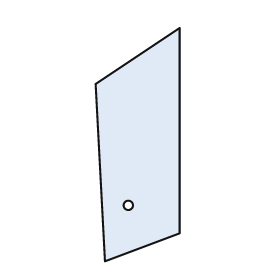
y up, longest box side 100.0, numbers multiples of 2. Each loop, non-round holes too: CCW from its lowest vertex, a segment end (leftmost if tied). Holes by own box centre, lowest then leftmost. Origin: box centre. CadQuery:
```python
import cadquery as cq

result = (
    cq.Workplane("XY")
    .moveTo(-14.0, -50.0)
    .lineTo(18.0, -38.0)
    .lineTo(18.0, 50.0)
    .lineTo(-18.0, 26.0)
    .close()
    .moveTo(-4.0, -26.0)
    .circle(2.0)
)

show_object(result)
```